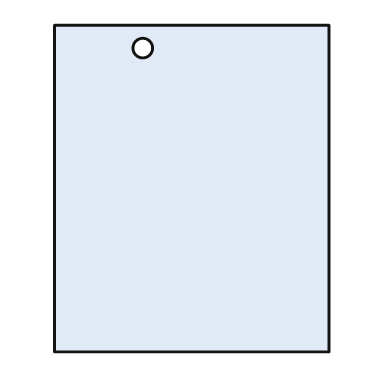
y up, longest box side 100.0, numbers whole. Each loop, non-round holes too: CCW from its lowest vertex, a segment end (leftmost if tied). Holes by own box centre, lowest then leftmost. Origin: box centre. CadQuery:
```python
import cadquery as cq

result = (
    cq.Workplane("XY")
    .moveTo(-42.0, -50.0)
    .lineTo(42.0, -50.0)
    .lineTo(42.0, 50.0)
    .lineTo(-42.0, 50.0)
    .close()
    .moveTo(-15.0, 43.0)
    .circle(3.0)
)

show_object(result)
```